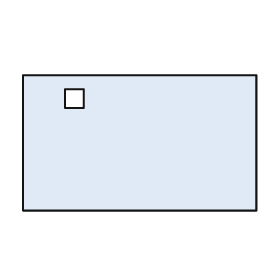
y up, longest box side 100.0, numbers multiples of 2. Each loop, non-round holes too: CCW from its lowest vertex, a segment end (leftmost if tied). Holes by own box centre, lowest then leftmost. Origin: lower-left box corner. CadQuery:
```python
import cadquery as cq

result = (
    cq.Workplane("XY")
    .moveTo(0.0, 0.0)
    .lineTo(100.0, 0.0)
    .lineTo(100.0, 58.0)
    .lineTo(0.0, 58.0)
    .close()
    .moveTo(18.0, 44.0)
    .lineTo(26.0, 44.0)
    .lineTo(26.0, 52.0)
    .lineTo(18.0, 52.0)
    .close()
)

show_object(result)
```